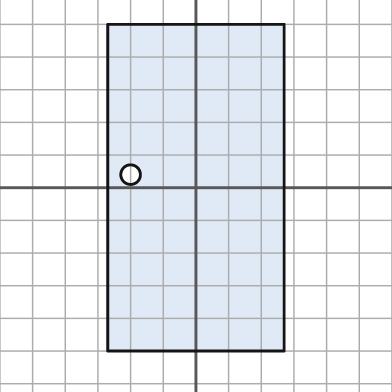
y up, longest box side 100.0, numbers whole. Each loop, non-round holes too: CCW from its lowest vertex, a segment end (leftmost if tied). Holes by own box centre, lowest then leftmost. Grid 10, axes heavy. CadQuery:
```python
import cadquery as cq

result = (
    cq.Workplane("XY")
    .moveTo(-27.0, -50.0)
    .lineTo(27.0, -50.0)
    .lineTo(27.0, 50.0)
    .lineTo(-27.0, 50.0)
    .close()
    .moveTo(-20.0, 4.0)
    .circle(3.0)
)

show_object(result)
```